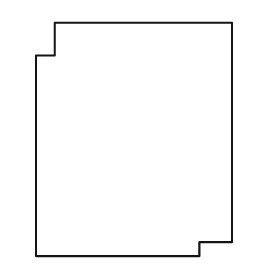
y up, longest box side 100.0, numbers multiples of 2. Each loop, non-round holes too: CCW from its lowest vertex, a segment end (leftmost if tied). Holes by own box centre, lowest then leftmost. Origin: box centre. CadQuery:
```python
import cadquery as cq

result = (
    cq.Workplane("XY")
    .moveTo(-42.0, -50.0)
    .lineTo(28.0, -50.0)
    .lineTo(28.0, -44.0)
    .lineTo(42.0, -44.0)
    .lineTo(42.0, 50.0)
    .lineTo(-34.0, 50.0)
    .lineTo(-34.0, 36.0)
    .lineTo(-42.0, 36.0)
    .close()
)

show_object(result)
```